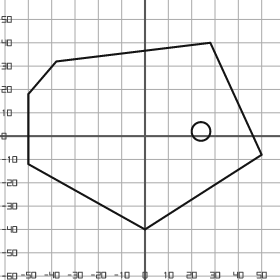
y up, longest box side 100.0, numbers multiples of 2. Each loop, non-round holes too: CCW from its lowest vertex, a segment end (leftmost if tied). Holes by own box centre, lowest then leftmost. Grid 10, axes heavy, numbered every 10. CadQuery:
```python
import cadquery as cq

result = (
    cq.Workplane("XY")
    .moveTo(0.0, -40.0)
    .lineTo(50.0, -8.0)
    .lineTo(28.0, 40.0)
    .lineTo(-38.0, 32.0)
    .lineTo(-50.0, 18.0)
    .lineTo(-50.0, -12.0)
    .close()
    .moveTo(24.0, 2.0)
    .circle(4.0)
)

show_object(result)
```